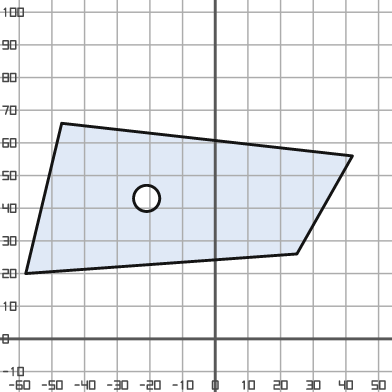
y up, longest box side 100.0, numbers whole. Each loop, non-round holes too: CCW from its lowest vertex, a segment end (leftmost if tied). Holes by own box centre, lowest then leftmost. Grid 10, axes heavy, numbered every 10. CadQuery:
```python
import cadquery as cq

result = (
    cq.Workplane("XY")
    .moveTo(-58.0, 20.0)
    .lineTo(25.0, 26.0)
    .lineTo(42.0, 56.0)
    .lineTo(-47.0, 66.0)
    .close()
    .moveTo(-21.0, 43.0)
    .circle(4.0)
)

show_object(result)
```